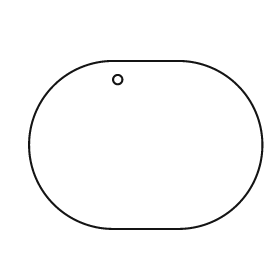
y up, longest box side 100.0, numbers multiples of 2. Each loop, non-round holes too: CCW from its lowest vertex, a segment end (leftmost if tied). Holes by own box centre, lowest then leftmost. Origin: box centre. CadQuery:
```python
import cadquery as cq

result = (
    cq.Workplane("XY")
    .moveTo(-14.0, -36.0)
    .lineTo(14.0, -36.0)
    .threePointArc((50.0, 0.0), (14.0, 36.0))
    .lineTo(-14.0, 36.0)
    .threePointArc((-50.0, 0.0), (-14.0, -36.0))
    .close()
    .moveTo(-12.0, 28.0)
    .circle(2.0)
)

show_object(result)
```